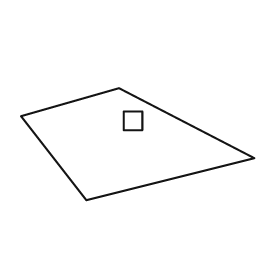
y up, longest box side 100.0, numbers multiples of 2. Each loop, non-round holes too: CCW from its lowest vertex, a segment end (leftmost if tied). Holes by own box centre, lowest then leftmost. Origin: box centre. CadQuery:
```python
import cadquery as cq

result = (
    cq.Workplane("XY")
    .moveTo(-22.0, -24.0)
    .lineTo(50.0, -6.0)
    .lineTo(-8.0, 24.0)
    .lineTo(-50.0, 12.0)
    .close()
    .moveTo(-6.0, 6.0)
    .lineTo(2.0, 6.0)
    .lineTo(2.0, 14.0)
    .lineTo(-6.0, 14.0)
    .close()
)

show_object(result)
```